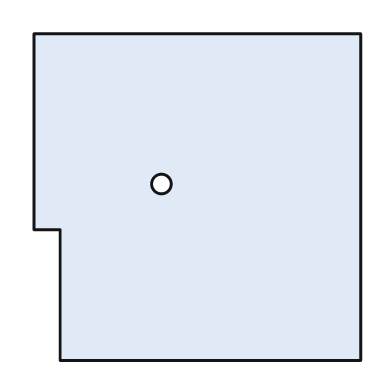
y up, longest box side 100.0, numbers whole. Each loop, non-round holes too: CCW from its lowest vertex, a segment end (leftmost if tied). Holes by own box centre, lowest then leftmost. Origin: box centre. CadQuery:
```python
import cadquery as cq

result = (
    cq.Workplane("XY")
    .moveTo(-42.0, -50.0)
    .lineTo(50.0, -50.0)
    .lineTo(50.0, 50.0)
    .lineTo(-50.0, 50.0)
    .lineTo(-50.0, -10.0)
    .lineTo(-42.0, -10.0)
    .close()
    .moveTo(-11.0, 4.0)
    .circle(3.0)
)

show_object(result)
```